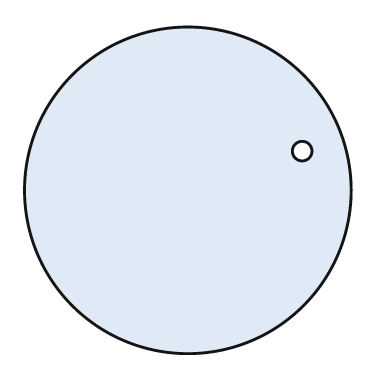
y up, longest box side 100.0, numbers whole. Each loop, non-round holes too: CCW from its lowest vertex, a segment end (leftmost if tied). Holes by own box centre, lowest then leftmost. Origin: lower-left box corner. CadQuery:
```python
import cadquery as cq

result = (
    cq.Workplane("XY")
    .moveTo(50.0, 50.0)
    .circle(50.0)
    .moveTo(85.0, 62.0)
    .circle(3.0)
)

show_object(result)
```